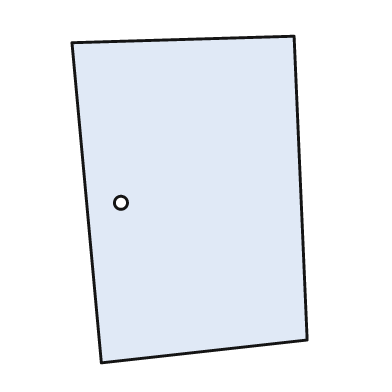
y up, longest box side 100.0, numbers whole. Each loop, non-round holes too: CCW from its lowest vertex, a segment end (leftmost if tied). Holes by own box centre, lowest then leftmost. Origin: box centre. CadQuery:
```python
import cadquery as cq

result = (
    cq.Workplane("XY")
    .moveTo(-27.0, -50.0)
    .lineTo(36.0, -43.0)
    .lineTo(32.0, 50.0)
    .lineTo(-36.0, 48.0)
    .close()
    .moveTo(-21.0, -1.0)
    .circle(2.0)
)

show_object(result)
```